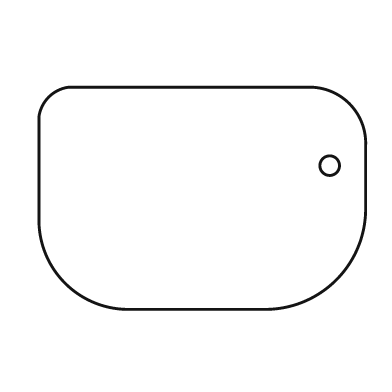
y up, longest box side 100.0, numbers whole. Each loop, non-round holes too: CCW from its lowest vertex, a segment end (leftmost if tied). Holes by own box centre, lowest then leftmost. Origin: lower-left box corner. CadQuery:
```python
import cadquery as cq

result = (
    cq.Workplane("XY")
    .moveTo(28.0, 0.0)
    .lineTo(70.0, 0.0)
    .threePointArc((91.0, 9.0), (100.0, 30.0))
    .lineTo(100.0, 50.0)
    .threePointArc((95.0, 63.0), (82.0, 68.0))
    .lineTo(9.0, 68.0)
    .threePointArc((3.0, 65.0), (0.0, 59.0))
    .lineTo(0.0, 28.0)
    .threePointArc((8.0, 8.0), (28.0, 0.0))
    .close()
    .moveTo(89.0, 44.0)
    .circle(3.0)
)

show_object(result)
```